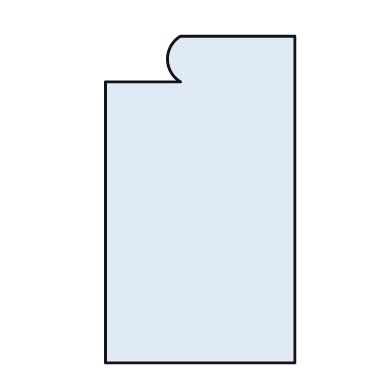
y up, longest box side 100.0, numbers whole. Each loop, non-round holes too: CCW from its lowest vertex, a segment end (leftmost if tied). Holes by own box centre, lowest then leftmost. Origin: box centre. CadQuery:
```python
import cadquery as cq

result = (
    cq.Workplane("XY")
    .moveTo(-29.0, -50.0)
    .lineTo(29.0, -50.0)
    .lineTo(29.0, 50.0)
    .lineTo(-6.0, 50.0)
    .threePointArc((-10.0, 43.0), (-6.0, 36.0))
    .lineTo(-29.0, 36.0)
    .close()
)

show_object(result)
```